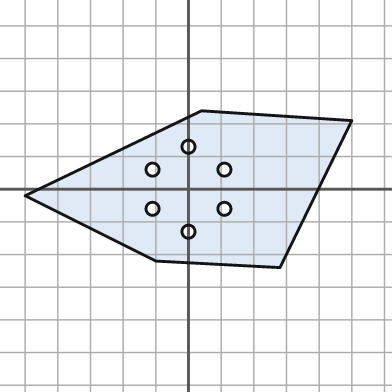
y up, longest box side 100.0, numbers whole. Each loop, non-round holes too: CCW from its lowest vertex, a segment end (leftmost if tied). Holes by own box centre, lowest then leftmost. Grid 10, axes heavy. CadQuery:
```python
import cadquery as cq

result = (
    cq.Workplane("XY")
    .moveTo(28.0, -24.0)
    .lineTo(50.0, 21.0)
    .lineTo(4.0, 24.0)
    .lineTo(-50.0, -2.0)
    .lineTo(-10.0, -22.0)
    .close()
    .moveTo(0.0, -13.0)
    .circle(2.0)
    .moveTo(-11.0, -6.0)
    .circle(2.0)
    .moveTo(11.0, -6.0)
    .circle(2.0)
    .moveTo(-11.0, 6.0)
    .circle(2.0)
    .moveTo(11.0, 6.0)
    .circle(2.0)
    .moveTo(0.0, 13.0)
    .circle(2.0)
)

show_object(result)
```